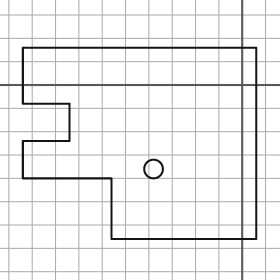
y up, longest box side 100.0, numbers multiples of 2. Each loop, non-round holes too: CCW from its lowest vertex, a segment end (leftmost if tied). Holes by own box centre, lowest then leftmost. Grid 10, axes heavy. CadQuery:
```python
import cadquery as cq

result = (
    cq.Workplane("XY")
    .moveTo(-56.0, -66.0)
    .lineTo(6.0, -66.0)
    .lineTo(6.0, 16.0)
    .lineTo(-94.0, 16.0)
    .lineTo(-94.0, -8.0)
    .lineTo(-74.0, -8.0)
    .lineTo(-74.0, -24.0)
    .lineTo(-94.0, -24.0)
    .lineTo(-94.0, -40.0)
    .lineTo(-56.0, -40.0)
    .close()
    .moveTo(-38.0, -36.0)
    .circle(4.0)
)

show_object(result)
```